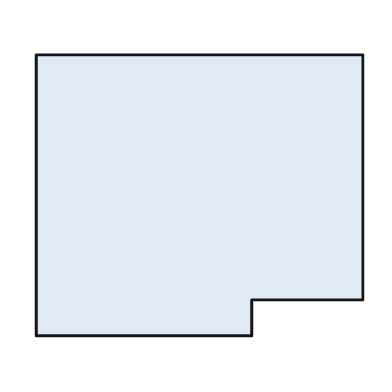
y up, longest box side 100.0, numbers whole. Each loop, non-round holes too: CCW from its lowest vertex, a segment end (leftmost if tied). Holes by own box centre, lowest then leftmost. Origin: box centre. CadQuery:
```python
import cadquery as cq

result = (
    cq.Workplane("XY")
    .moveTo(-50.0, -43.0)
    .lineTo(16.0, -43.0)
    .lineTo(16.0, -32.0)
    .lineTo(50.0, -32.0)
    .lineTo(50.0, 43.0)
    .lineTo(-50.0, 43.0)
    .close()
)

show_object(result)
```